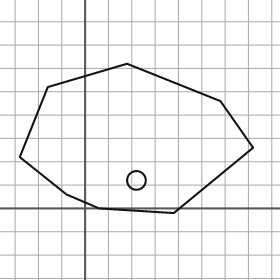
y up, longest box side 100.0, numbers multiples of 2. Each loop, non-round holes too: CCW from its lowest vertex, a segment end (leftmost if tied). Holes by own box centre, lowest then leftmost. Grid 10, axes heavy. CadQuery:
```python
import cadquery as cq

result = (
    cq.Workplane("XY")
    .moveTo(38.0, -2.0)
    .lineTo(72.0, 26.0)
    .lineTo(58.0, 46.0)
    .lineTo(18.0, 62.0)
    .lineTo(-16.0, 52.0)
    .lineTo(-28.0, 22.0)
    .lineTo(-8.0, 6.0)
    .lineTo(6.0, 0.0)
    .close()
    .moveTo(22.0, 12.0)
    .circle(4.0)
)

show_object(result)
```